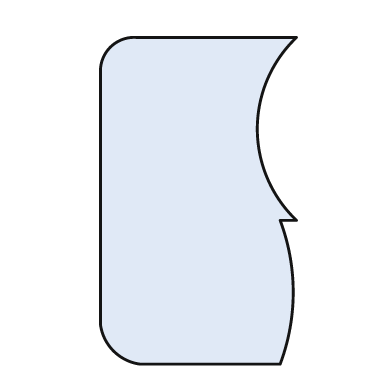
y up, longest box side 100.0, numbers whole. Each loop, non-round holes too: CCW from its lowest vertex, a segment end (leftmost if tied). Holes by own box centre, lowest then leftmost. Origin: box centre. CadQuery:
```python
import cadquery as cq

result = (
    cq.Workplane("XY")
    .moveTo(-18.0, -50.0)
    .lineTo(25.0, -50.0)
    .threePointArc((29.0, -28.0), (25.0, -6.0))
    .lineTo(30.0, -6.0)
    .threePointArc((18.0, 22.0), (30.0, 50.0))
    .lineTo(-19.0, 50.0)
    .threePointArc((-27.0, 47.0), (-30.0, 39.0))
    .lineTo(-30.0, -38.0)
    .threePointArc((-26.0, -46.0), (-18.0, -50.0))
    .close()
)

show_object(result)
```